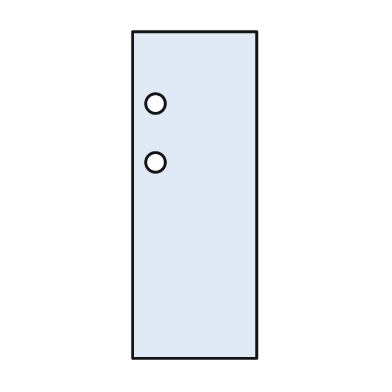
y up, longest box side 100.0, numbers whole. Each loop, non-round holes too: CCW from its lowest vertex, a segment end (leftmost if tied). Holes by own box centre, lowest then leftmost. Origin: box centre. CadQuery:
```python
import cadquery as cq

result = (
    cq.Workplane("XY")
    .moveTo(-19.0, -50.0)
    .lineTo(19.0, -50.0)
    .lineTo(19.0, 50.0)
    .lineTo(-19.0, 50.0)
    .close()
    .moveTo(-12.0, 10.0)
    .circle(3.0)
    .moveTo(-12.0, 28.0)
    .circle(3.0)
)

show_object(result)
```